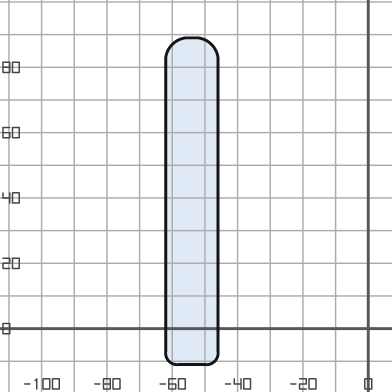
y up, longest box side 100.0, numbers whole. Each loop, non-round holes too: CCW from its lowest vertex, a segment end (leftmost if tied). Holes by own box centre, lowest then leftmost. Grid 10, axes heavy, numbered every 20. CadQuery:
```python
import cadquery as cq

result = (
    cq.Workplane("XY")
    .moveTo(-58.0, -11.0)
    .lineTo(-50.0, -11.0)
    .threePointArc((-47.0, -10.0), (-46.0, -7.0))
    .lineTo(-46.0, 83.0)
    .threePointArc((-48.0, 87.0), (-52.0, 89.0))
    .lineTo(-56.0, 89.0)
    .threePointArc((-60.0, 87.0), (-62.0, 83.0))
    .lineTo(-62.0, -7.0)
    .threePointArc((-61.0, -10.0), (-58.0, -11.0))
    .close()
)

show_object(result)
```